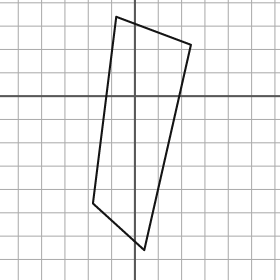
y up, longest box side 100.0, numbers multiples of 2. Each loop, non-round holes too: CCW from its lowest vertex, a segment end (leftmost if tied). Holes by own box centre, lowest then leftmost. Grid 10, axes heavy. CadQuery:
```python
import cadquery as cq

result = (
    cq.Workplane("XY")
    .moveTo(4.0, -66.0)
    .lineTo(24.0, 22.0)
    .lineTo(-8.0, 34.0)
    .lineTo(-18.0, -46.0)
    .close()
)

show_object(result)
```